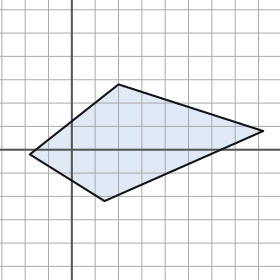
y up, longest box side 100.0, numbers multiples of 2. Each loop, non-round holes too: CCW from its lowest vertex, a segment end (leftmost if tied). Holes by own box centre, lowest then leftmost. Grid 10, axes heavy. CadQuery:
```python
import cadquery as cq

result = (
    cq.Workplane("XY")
    .moveTo(14.0, -22.0)
    .lineTo(82.0, 8.0)
    .lineTo(20.0, 28.0)
    .lineTo(-18.0, -2.0)
    .close()
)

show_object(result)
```